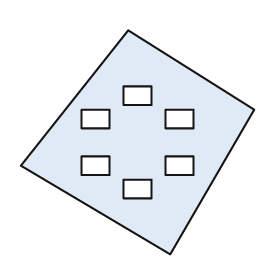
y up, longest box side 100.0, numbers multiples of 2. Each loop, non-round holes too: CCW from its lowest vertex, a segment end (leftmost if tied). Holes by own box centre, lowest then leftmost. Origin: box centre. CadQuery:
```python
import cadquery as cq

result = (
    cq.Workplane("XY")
    .moveTo(14.0, -48.0)
    .lineTo(50.0, 14.0)
    .lineTo(-4.0, 48.0)
    .lineTo(-50.0, -10.0)
    .close()
    .moveTo(-6.0, -24.0)
    .lineTo(6.0, -24.0)
    .lineTo(6.0, -16.0)
    .lineTo(-6.0, -16.0)
    .close()
    .moveTo(-24.0, -14.0)
    .lineTo(-12.0, -14.0)
    .lineTo(-12.0, -6.0)
    .lineTo(-24.0, -6.0)
    .close()
    .moveTo(12.0, -14.0)
    .lineTo(24.0, -14.0)
    .lineTo(24.0, -6.0)
    .lineTo(12.0, -6.0)
    .close()
    .moveTo(-24.0, 6.0)
    .lineTo(-12.0, 6.0)
    .lineTo(-12.0, 14.0)
    .lineTo(-24.0, 14.0)
    .close()
    .moveTo(12.0, 6.0)
    .lineTo(24.0, 6.0)
    .lineTo(24.0, 14.0)
    .lineTo(12.0, 14.0)
    .close()
    .moveTo(-6.0, 16.0)
    .lineTo(6.0, 16.0)
    .lineTo(6.0, 24.0)
    .lineTo(-6.0, 24.0)
    .close()
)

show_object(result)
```